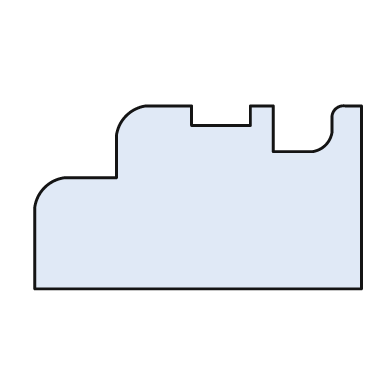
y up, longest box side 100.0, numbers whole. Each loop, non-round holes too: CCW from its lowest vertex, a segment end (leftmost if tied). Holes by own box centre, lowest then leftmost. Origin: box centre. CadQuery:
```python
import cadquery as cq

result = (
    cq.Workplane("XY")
    .moveTo(-50.0, -28.0)
    .lineTo(50.0, -28.0)
    .lineTo(50.0, 28.0)
    .lineTo(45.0, 28.0)
    .threePointArc((42.0, 27.0), (41.0, 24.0))
    .lineTo(41.0, 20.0)
    .threePointArc((39.0, 16.0), (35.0, 14.0))
    .lineTo(23.0, 14.0)
    .lineTo(23.0, 28.0)
    .lineTo(16.0, 28.0)
    .lineTo(16.0, 22.0)
    .lineTo(-2.0, 22.0)
    .lineTo(-2.0, 28.0)
    .lineTo(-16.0, 28.0)
    .threePointArc((-22.0, 25.0), (-25.0, 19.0))
    .lineTo(-25.0, 6.0)
    .lineTo(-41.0, 6.0)
    .threePointArc((-47.0, 3.0), (-50.0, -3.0))
    .close()
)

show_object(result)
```